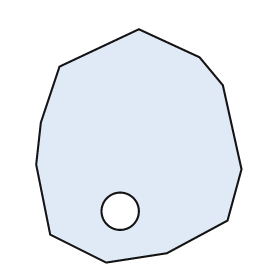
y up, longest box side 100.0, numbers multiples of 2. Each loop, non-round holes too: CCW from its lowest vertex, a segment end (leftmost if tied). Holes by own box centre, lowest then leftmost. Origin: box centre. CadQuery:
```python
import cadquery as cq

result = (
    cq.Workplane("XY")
    .moveTo(-14.0, -50.0)
    .lineTo(12.0, -46.0)
    .lineTo(38.0, -32.0)
    .lineTo(44.0, -10.0)
    .lineTo(36.0, 26.0)
    .lineTo(26.0, 38.0)
    .lineTo(0.0, 50.0)
    .lineTo(-34.0, 34.0)
    .lineTo(-42.0, 10.0)
    .lineTo(-44.0, -8.0)
    .lineTo(-38.0, -38.0)
    .close()
    .moveTo(-8.0, -28.0)
    .circle(8.0)
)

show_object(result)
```